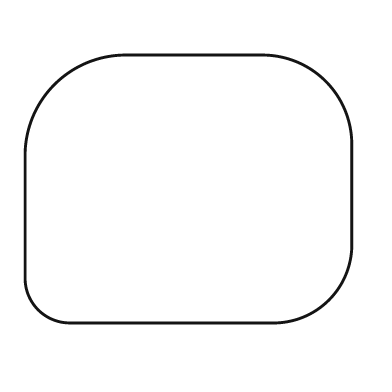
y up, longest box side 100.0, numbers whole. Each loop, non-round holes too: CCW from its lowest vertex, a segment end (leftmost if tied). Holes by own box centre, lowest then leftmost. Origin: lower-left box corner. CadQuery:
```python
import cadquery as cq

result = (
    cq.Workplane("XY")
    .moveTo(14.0, 0.0)
    .lineTo(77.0, 0.0)
    .threePointArc((93.0, 7.0), (100.0, 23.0))
    .lineTo(100.0, 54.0)
    .threePointArc((92.0, 74.0), (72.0, 82.0))
    .lineTo(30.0, 82.0)
    .threePointArc((9.0, 73.0), (0.0, 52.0))
    .lineTo(0.0, 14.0)
    .threePointArc((4.0, 4.0), (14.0, 0.0))
    .close()
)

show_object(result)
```